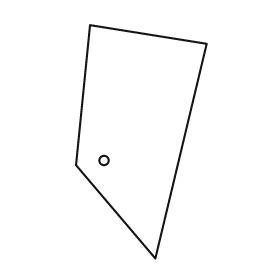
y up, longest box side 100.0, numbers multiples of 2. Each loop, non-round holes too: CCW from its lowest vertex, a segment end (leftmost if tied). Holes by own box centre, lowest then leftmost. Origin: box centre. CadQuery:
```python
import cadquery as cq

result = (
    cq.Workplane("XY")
    .moveTo(6.0, -50.0)
    .lineTo(28.0, 42.0)
    .lineTo(-22.0, 50.0)
    .lineTo(-28.0, -10.0)
    .close()
    .moveTo(-16.0, -8.0)
    .circle(2.0)
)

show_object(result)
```